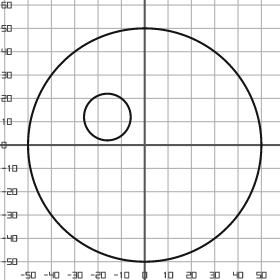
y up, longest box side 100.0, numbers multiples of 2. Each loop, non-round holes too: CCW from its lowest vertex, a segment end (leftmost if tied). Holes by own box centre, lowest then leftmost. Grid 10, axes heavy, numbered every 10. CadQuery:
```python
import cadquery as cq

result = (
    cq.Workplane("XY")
    .moveTo(0.0, 0.0)
    .circle(50.0)
    .moveTo(-16.0, 12.0)
    .circle(10.0)
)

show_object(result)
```